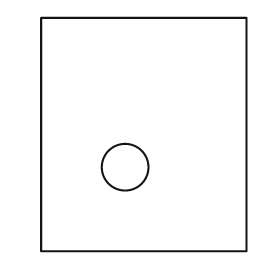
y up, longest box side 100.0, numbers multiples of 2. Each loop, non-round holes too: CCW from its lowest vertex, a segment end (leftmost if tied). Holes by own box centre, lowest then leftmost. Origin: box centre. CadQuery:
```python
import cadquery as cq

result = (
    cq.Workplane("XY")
    .moveTo(-44.0, -50.0)
    .lineTo(44.0, -50.0)
    .lineTo(44.0, 50.0)
    .lineTo(-44.0, 50.0)
    .close()
    .moveTo(-8.0, -14.0)
    .circle(10.0)
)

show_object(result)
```